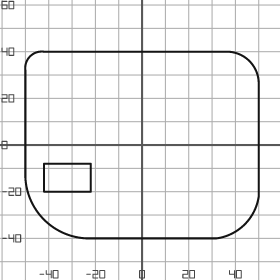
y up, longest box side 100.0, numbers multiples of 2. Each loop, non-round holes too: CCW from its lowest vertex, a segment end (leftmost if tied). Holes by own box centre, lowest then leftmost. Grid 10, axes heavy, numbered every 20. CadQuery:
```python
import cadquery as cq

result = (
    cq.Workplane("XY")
    .moveTo(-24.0, -40.0)
    .lineTo(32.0, -40.0)
    .threePointArc((44.0, -34.0), (50.0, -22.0))
    .lineTo(50.0, 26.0)
    .threePointArc((46.0, 36.0), (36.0, 40.0))
    .lineTo(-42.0, 40.0)
    .threePointArc((-48.0, 38.0), (-50.0, 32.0))
    .lineTo(-50.0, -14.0)
    .threePointArc((-42.0, -32.0), (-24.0, -40.0))
    .close()
    .moveTo(-42.0, -20.0)
    .lineTo(-22.0, -20.0)
    .lineTo(-22.0, -8.0)
    .lineTo(-42.0, -8.0)
    .close()
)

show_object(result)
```